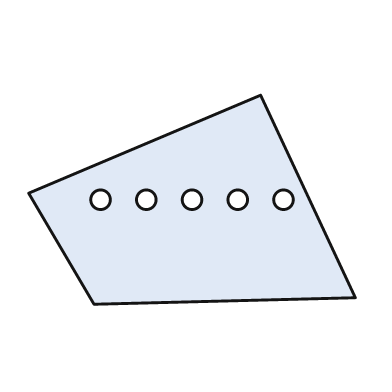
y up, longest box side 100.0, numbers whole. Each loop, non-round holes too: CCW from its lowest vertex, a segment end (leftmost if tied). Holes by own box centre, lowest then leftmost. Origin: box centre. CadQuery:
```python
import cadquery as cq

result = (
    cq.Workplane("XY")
    .moveTo(-30.0, -32.0)
    .lineTo(50.0, -30.0)
    .lineTo(21.0, 32.0)
    .lineTo(-50.0, 2.0)
    .close()
    .moveTo(-28.0, 0.0)
    .circle(3.0)
    .moveTo(-14.0, 0.0)
    .circle(3.0)
    .moveTo(0.0, 0.0)
    .circle(3.0)
    .moveTo(14.0, 0.0)
    .circle(3.0)
    .moveTo(28.0, 0.0)
    .circle(3.0)
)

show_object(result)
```